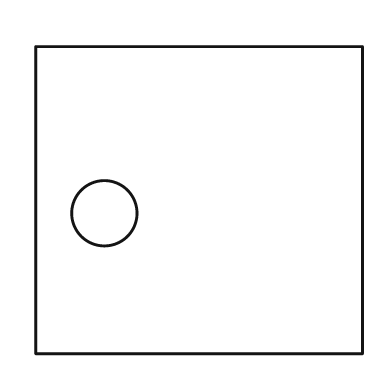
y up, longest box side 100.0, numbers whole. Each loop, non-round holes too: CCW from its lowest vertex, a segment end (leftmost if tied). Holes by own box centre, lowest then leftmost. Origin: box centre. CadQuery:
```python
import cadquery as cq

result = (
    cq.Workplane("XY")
    .moveTo(-50.0, -47.0)
    .lineTo(50.0, -47.0)
    .lineTo(50.0, 47.0)
    .lineTo(-50.0, 47.0)
    .close()
    .moveTo(-29.0, -4.0)
    .circle(10.0)
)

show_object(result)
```